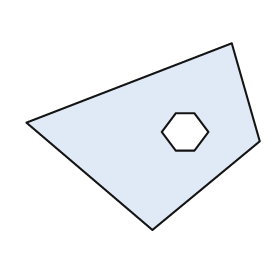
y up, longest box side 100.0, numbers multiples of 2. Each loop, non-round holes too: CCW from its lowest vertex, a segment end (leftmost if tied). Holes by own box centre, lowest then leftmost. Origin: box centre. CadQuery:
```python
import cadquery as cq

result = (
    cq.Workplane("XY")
    .moveTo(4.0, -40.0)
    .lineTo(50.0, -2.0)
    .lineTo(38.0, 40.0)
    .lineTo(-50.0, 6.0)
    .close()
    .moveTo(14.0, -6.0)
    .lineTo(22.0, -6.0)
    .lineTo(28.0, 2.0)
    .lineTo(22.0, 10.0)
    .lineTo(14.0, 10.0)
    .lineTo(8.0, 2.0)
    .close()
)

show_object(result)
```